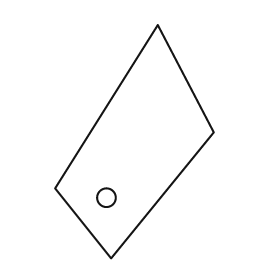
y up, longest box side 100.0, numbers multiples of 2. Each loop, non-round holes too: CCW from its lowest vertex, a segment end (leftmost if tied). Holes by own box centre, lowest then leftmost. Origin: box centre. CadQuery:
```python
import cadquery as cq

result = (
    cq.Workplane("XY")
    .moveTo(-10.0, -50.0)
    .lineTo(34.0, 4.0)
    .lineTo(10.0, 50.0)
    .lineTo(-34.0, -20.0)
    .close()
    .moveTo(-12.0, -24.0)
    .circle(4.0)
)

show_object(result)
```